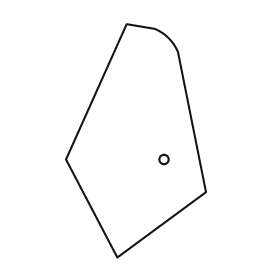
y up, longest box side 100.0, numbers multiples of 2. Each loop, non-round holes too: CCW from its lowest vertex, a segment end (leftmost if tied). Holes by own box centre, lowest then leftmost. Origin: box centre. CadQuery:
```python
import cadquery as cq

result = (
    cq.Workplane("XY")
    .moveTo(-8.0, -50.0)
    .lineTo(30.0, -22.0)
    .lineTo(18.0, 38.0)
    .threePointArc((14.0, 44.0), (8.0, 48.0))
    .lineTo(-4.0, 50.0)
    .lineTo(-30.0, -8.0)
    .close()
    .moveTo(12.0, -8.0)
    .circle(2.0)
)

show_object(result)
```